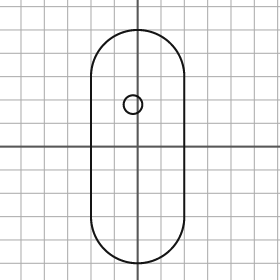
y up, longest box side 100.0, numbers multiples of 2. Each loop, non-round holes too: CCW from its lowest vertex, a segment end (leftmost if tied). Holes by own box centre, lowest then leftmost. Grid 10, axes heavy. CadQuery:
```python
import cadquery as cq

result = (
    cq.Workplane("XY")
    .moveTo(-20.0, -30.0)
    .threePointArc((0.0, -50.0), (20.0, -30.0))
    .lineTo(20.0, 30.0)
    .threePointArc((0.0, 50.0), (-20.0, 30.0))
    .close()
    .moveTo(-2.0, 18.0)
    .circle(4.0)
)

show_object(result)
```